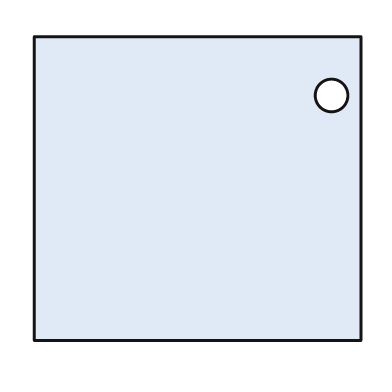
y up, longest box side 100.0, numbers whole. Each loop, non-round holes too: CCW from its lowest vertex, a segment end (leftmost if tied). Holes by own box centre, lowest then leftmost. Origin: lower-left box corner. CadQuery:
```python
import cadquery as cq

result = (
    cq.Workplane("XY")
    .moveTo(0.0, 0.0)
    .lineTo(100.0, 0.0)
    .lineTo(100.0, 93.0)
    .lineTo(0.0, 93.0)
    .close()
    .moveTo(91.0, 75.0)
    .circle(5.0)
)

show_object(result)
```